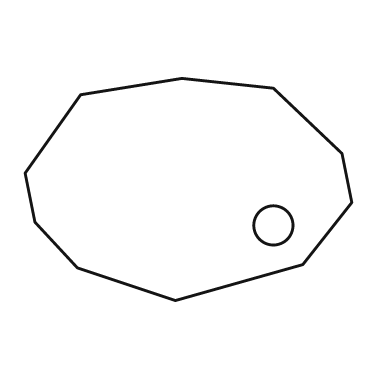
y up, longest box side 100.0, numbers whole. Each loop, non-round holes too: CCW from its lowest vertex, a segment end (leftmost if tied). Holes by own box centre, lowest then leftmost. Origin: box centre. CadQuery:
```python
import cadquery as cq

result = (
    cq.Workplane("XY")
    .moveTo(-4.0, -34.0)
    .lineTo(35.0, -23.0)
    .lineTo(50.0, -4.0)
    .lineTo(47.0, 11.0)
    .lineTo(26.0, 31.0)
    .lineTo(-2.0, 34.0)
    .lineTo(-33.0, 29.0)
    .lineTo(-50.0, 5.0)
    .lineTo(-47.0, -10.0)
    .lineTo(-34.0, -24.0)
    .close()
    .moveTo(26.0, -11.0)
    .circle(6.0)
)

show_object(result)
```